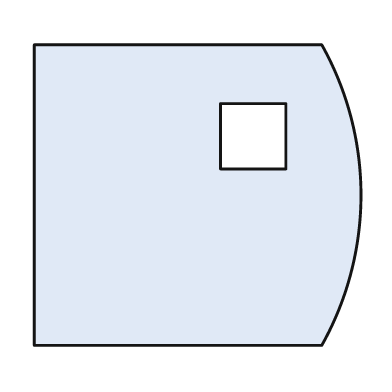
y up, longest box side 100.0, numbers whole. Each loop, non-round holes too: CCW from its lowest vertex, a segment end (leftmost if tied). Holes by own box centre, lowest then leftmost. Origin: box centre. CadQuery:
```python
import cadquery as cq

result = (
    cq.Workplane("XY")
    .moveTo(-50.0, -46.0)
    .lineTo(38.0, -46.0)
    .threePointArc((50.0, 0.0), (38.0, 46.0))
    .lineTo(-50.0, 46.0)
    .close()
    .moveTo(7.0, 8.0)
    .lineTo(27.0, 8.0)
    .lineTo(27.0, 28.0)
    .lineTo(7.0, 28.0)
    .close()
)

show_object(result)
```